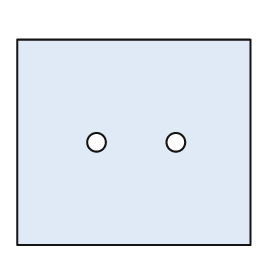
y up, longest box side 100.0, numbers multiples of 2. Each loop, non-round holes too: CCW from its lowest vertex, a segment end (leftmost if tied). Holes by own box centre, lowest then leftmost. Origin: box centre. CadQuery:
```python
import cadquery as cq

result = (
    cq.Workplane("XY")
    .moveTo(-50.0, -44.0)
    .lineTo(50.0, -44.0)
    .lineTo(50.0, 44.0)
    .lineTo(-50.0, 44.0)
    .close()
    .moveTo(-16.0, 0.0)
    .circle(4.0)
    .moveTo(18.0, 0.0)
    .circle(4.0)
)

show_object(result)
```